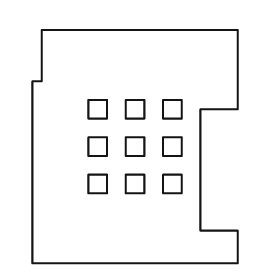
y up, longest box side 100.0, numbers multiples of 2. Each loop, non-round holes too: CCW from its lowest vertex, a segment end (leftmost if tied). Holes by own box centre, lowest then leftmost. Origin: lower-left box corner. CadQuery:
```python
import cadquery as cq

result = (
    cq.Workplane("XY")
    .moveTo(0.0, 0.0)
    .lineTo(88.0, 0.0)
    .lineTo(88.0, 14.0)
    .lineTo(72.0, 14.0)
    .lineTo(72.0, 66.0)
    .lineTo(88.0, 66.0)
    .lineTo(88.0, 100.0)
    .lineTo(4.0, 100.0)
    .lineTo(4.0, 78.0)
    .lineTo(0.0, 78.0)
    .close()
    .moveTo(24.0, 30.0)
    .lineTo(32.0, 30.0)
    .lineTo(32.0, 38.0)
    .lineTo(24.0, 38.0)
    .close()
    .moveTo(40.0, 30.0)
    .lineTo(48.0, 30.0)
    .lineTo(48.0, 38.0)
    .lineTo(40.0, 38.0)
    .close()
    .moveTo(56.0, 30.0)
    .lineTo(64.0, 30.0)
    .lineTo(64.0, 38.0)
    .lineTo(56.0, 38.0)
    .close()
    .moveTo(24.0, 46.0)
    .lineTo(32.0, 46.0)
    .lineTo(32.0, 54.0)
    .lineTo(24.0, 54.0)
    .close()
    .moveTo(40.0, 46.0)
    .lineTo(48.0, 46.0)
    .lineTo(48.0, 54.0)
    .lineTo(40.0, 54.0)
    .close()
    .moveTo(56.0, 46.0)
    .lineTo(64.0, 46.0)
    .lineTo(64.0, 54.0)
    .lineTo(56.0, 54.0)
    .close()
    .moveTo(24.0, 62.0)
    .lineTo(32.0, 62.0)
    .lineTo(32.0, 70.0)
    .lineTo(24.0, 70.0)
    .close()
    .moveTo(40.0, 62.0)
    .lineTo(48.0, 62.0)
    .lineTo(48.0, 70.0)
    .lineTo(40.0, 70.0)
    .close()
    .moveTo(56.0, 62.0)
    .lineTo(64.0, 62.0)
    .lineTo(64.0, 70.0)
    .lineTo(56.0, 70.0)
    .close()
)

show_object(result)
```